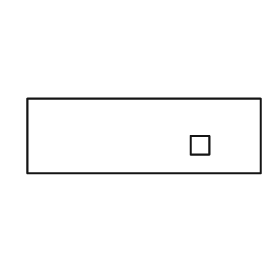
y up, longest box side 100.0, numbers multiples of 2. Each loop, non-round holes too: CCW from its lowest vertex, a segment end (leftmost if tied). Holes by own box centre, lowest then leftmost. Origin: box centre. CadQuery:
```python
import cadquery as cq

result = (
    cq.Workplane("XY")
    .moveTo(-50.0, -16.0)
    .lineTo(50.0, -16.0)
    .lineTo(50.0, 16.0)
    .lineTo(-50.0, 16.0)
    .close()
    .moveTo(20.0, -8.0)
    .lineTo(28.0, -8.0)
    .lineTo(28.0, 0.0)
    .lineTo(20.0, 0.0)
    .close()
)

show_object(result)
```